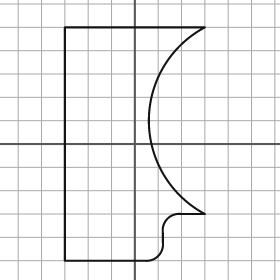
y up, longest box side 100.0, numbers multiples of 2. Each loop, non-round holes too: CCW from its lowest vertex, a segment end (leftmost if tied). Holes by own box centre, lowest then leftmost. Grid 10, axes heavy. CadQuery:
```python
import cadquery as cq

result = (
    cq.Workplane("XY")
    .moveTo(-30.0, -50.0)
    .lineTo(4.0, -50.0)
    .threePointArc((10.0, -48.0), (12.0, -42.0))
    .lineTo(12.0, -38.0)
    .threePointArc((14.0, -32.0), (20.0, -30.0))
    .lineTo(30.0, -30.0)
    .threePointArc((6.0, 10.0), (30.0, 50.0))
    .lineTo(-30.0, 50.0)
    .close()
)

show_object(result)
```